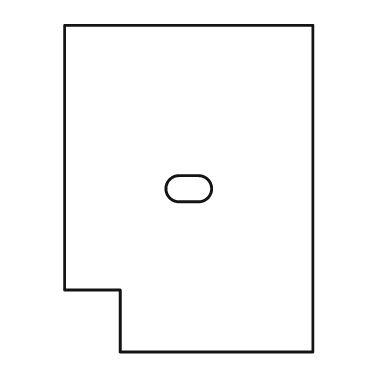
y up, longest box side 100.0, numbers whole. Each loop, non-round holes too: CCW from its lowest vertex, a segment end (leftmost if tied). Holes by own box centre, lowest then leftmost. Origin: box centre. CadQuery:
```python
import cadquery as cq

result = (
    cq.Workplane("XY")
    .moveTo(-21.0, -50.0)
    .lineTo(38.0, -50.0)
    .lineTo(38.0, 50.0)
    .lineTo(-38.0, 50.0)
    .lineTo(-38.0, -31.0)
    .lineTo(-21.0, -31.0)
    .close()
    .moveTo(-3.0, -4.0)
    .lineTo(3.0, -4.0)
    .threePointArc((7.0, 0.0), (3.0, 4.0))
    .lineTo(-3.0, 4.0)
    .threePointArc((-7.0, 0.0), (-3.0, -4.0))
    .close()
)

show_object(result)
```